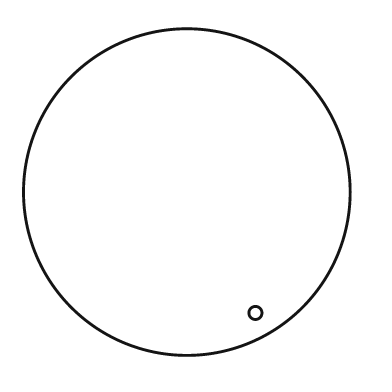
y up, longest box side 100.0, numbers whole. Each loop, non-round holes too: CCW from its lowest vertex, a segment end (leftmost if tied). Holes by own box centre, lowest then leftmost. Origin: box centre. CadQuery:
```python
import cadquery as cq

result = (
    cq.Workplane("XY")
    .moveTo(0.0, 0.0)
    .circle(50.0)
    .moveTo(21.0, -37.0)
    .circle(2.0)
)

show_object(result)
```